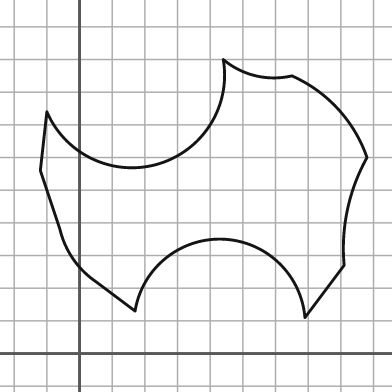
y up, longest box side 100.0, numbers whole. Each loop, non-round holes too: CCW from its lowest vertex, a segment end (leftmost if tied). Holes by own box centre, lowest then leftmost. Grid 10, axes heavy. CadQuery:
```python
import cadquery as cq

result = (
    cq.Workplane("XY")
    .moveTo(69.0, 11.0)
    .lineTo(81.0, 27.0)
    .threePointArc((82.0, 44.0), (88.0, 60.0))
    .threePointArc((79.0, 75.0), (65.0, 85.0))
    .threePointArc((54.0, 85.0), (44.0, 90.0))
    .threePointArc((24.0, 58.0), (-10.0, 74.0))
    .lineTo(-12.0, 56.0)
    .lineTo(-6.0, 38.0)
    .threePointArc((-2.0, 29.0), (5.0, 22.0))
    .lineTo(17.0, 13.0)
    .threePointArc((44.0, 35.0), (69.0, 11.0))
    .close()
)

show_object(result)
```